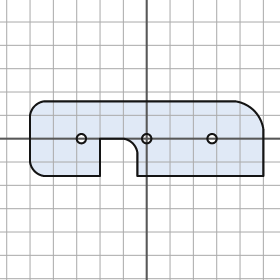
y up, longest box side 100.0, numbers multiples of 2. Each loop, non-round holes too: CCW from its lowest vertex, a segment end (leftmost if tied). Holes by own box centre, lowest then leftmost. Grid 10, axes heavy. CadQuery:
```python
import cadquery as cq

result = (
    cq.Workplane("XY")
    .moveTo(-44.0, -16.0)
    .lineTo(-20.0, -16.0)
    .lineTo(-20.0, 0.0)
    .lineTo(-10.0, 0.0)
    .threePointArc((-6.0, -2.0), (-4.0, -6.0))
    .lineTo(-4.0, -16.0)
    .lineTo(50.0, -16.0)
    .lineTo(50.0, 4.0)
    .threePointArc((46.0, 12.0), (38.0, 16.0))
    .lineTo(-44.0, 16.0)
    .threePointArc((-48.0, 14.0), (-50.0, 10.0))
    .lineTo(-50.0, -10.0)
    .threePointArc((-48.0, -14.0), (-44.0, -16.0))
    .close()
    .moveTo(-28.0, 0.0)
    .circle(2.0)
    .moveTo(0.0, 0.0)
    .circle(2.0)
    .moveTo(28.0, 0.0)
    .circle(2.0)
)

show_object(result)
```